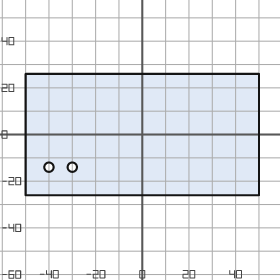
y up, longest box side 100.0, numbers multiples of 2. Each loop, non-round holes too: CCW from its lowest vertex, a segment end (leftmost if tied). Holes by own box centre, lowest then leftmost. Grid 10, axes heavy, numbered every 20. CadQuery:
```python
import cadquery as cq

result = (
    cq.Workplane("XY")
    .moveTo(-50.0, -26.0)
    .lineTo(50.0, -26.0)
    .lineTo(50.0, 26.0)
    .lineTo(-50.0, 26.0)
    .close()
    .moveTo(-40.0, -14.0)
    .circle(2.0)
    .moveTo(-30.0, -14.0)
    .circle(2.0)
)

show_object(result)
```